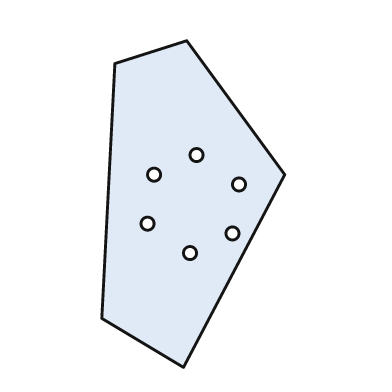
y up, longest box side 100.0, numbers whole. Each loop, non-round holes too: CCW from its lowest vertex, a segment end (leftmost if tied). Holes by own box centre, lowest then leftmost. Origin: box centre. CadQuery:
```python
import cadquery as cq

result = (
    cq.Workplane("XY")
    .moveTo(-3.0, -50.0)
    .lineTo(28.0, 9.0)
    .lineTo(-2.0, 50.0)
    .lineTo(-24.0, 43.0)
    .lineTo(-28.0, -35.0)
    .close()
    .moveTo(-1.0, -15.0)
    .circle(2.0)
    .moveTo(12.0, -9.0)
    .circle(2.0)
    .moveTo(-14.0, -6.0)
    .circle(2.0)
    .moveTo(14.0, 6.0)
    .circle(2.0)
    .moveTo(-12.0, 9.0)
    .circle(2.0)
    .moveTo(1.0, 15.0)
    .circle(2.0)
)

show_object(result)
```